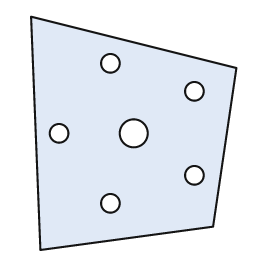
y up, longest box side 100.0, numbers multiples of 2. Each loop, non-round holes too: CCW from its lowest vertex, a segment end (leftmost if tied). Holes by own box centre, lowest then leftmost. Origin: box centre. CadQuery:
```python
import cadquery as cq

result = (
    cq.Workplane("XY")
    .moveTo(-40.0, -50.0)
    .lineTo(34.0, -40.0)
    .lineTo(44.0, 28.0)
    .lineTo(-44.0, 50.0)
    .close()
    .moveTo(-10.0, -30.0)
    .circle(4.0)
    .moveTo(26.0, -18.0)
    .circle(4.0)
    .moveTo(-32.0, 0.0)
    .circle(4.0)
    .moveTo(0.0, 0.0)
    .circle(6.0)
    .moveTo(26.0, 18.0)
    .circle(4.0)
    .moveTo(-10.0, 30.0)
    .circle(4.0)
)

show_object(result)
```